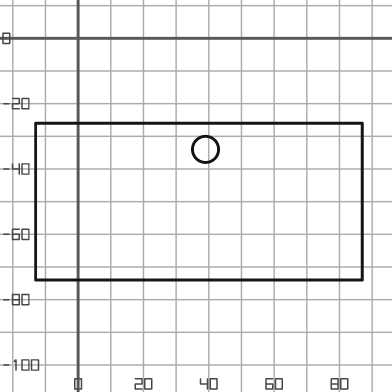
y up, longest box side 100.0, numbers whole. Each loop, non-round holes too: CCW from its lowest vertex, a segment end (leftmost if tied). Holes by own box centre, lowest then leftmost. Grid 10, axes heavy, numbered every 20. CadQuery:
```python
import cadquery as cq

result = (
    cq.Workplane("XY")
    .moveTo(-13.0, -74.0)
    .lineTo(87.0, -74.0)
    .lineTo(87.0, -26.0)
    .lineTo(-13.0, -26.0)
    .close()
    .moveTo(39.0, -34.0)
    .circle(4.0)
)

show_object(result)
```